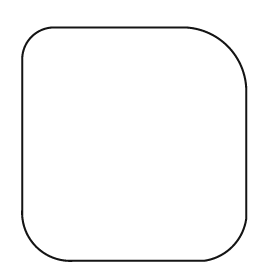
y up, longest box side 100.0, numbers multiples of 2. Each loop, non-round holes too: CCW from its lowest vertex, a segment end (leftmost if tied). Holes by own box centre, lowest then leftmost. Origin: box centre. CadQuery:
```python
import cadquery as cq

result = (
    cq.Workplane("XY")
    .moveTo(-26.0, -50.0)
    .lineTo(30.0, -50.0)
    .threePointArc((42.0, -44.0), (48.0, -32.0))
    .lineTo(48.0, 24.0)
    .threePointArc((40.0, 42.0), (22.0, 50.0))
    .lineTo(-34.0, 50.0)
    .threePointArc((-44.0, 46.0), (-48.0, 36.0))
    .lineTo(-48.0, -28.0)
    .threePointArc((-42.0, -44.0), (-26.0, -50.0))
    .close()
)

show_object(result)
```